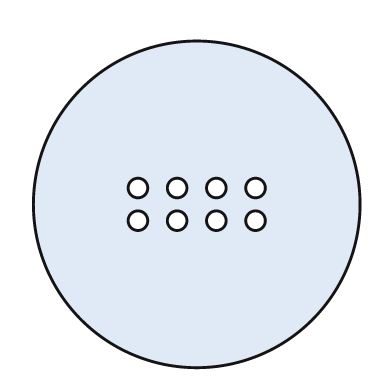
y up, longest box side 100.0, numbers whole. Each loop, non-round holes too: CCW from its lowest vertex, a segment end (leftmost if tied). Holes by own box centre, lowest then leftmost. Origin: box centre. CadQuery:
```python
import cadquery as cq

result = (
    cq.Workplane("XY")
    .moveTo(0.0, 0.0)
    .circle(50.0)
    .moveTo(-18.0, -5.0)
    .circle(3.0)
    .moveTo(-6.0, -5.0)
    .circle(3.0)
    .moveTo(6.0, -5.0)
    .circle(3.0)
    .moveTo(18.0, -5.0)
    .circle(3.0)
    .moveTo(-18.0, 5.0)
    .circle(3.0)
    .moveTo(-6.0, 5.0)
    .circle(3.0)
    .moveTo(6.0, 5.0)
    .circle(3.0)
    .moveTo(18.0, 5.0)
    .circle(3.0)
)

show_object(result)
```